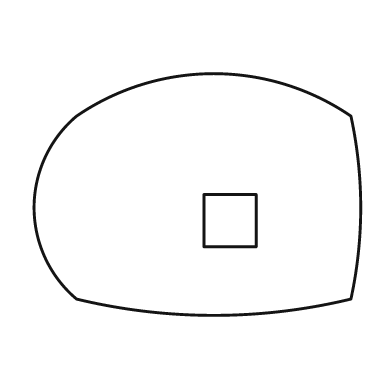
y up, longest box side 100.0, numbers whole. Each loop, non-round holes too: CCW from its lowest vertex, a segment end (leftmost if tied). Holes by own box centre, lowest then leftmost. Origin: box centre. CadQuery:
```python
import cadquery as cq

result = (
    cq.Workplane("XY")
    .moveTo(-37.0, -32.0)
    .threePointArc((5.0, -37.0), (47.0, -32.0))
    .threePointArc((50.0, -4.0), (47.0, 24.0))
    .threePointArc((5.0, 37.0), (-37.0, 24.0))
    .threePointArc((-50.0, -4.0), (-37.0, -32.0))
    .close()
    .moveTo(2.0, -16.0)
    .lineTo(18.0, -16.0)
    .lineTo(18.0, 0.0)
    .lineTo(2.0, 0.0)
    .close()
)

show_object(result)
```